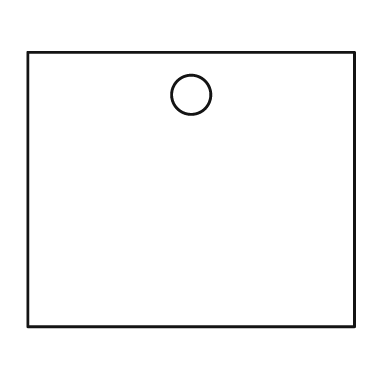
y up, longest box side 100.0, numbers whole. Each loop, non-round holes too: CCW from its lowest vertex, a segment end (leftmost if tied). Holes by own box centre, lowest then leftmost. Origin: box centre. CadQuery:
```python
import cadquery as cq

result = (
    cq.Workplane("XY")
    .moveTo(-50.0, -42.0)
    .lineTo(50.0, -42.0)
    .lineTo(50.0, 42.0)
    .lineTo(-50.0, 42.0)
    .close()
    .moveTo(0.0, 29.0)
    .circle(6.0)
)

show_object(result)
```